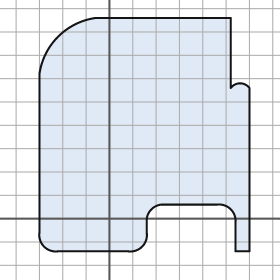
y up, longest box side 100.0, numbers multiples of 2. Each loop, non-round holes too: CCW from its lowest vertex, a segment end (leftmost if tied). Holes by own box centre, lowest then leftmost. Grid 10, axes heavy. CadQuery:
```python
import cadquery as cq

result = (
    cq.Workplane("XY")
    .moveTo(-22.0, -14.0)
    .lineTo(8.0, -14.0)
    .threePointArc((14.0, -12.0), (16.0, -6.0))
    .lineTo(16.0, 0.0)
    .threePointArc((18.0, 4.0), (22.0, 6.0))
    .lineTo(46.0, 6.0)
    .threePointArc((52.0, 4.0), (54.0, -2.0))
    .lineTo(54.0, -14.0)
    .lineTo(60.0, -14.0)
    .lineTo(60.0, 56.0)
    .threePointArc((56.0, 58.0), (52.0, 56.0))
    .lineTo(52.0, 86.0)
    .lineTo(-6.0, 86.0)
    .threePointArc((-22.0, 78.0), (-30.0, 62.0))
    .lineTo(-30.0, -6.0)
    .threePointArc((-28.0, -12.0), (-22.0, -14.0))
    .close()
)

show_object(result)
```